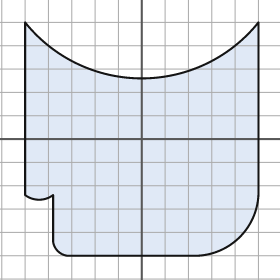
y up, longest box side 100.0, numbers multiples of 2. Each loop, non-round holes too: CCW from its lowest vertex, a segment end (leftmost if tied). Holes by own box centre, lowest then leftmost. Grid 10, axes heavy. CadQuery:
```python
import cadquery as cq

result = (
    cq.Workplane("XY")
    .moveTo(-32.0, -50.0)
    .lineTo(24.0, -50.0)
    .threePointArc((42.0, -42.0), (50.0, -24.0))
    .lineTo(50.0, 50.0)
    .threePointArc((0.0, 26.0), (-50.0, 50.0))
    .lineTo(-50.0, -24.0)
    .threePointArc((-44.0, -26.0), (-38.0, -24.0))
    .lineTo(-38.0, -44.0)
    .threePointArc((-36.0, -48.0), (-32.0, -50.0))
    .close()
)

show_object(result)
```